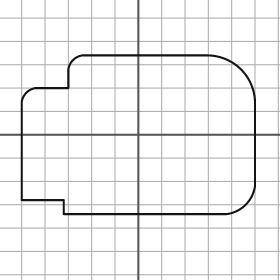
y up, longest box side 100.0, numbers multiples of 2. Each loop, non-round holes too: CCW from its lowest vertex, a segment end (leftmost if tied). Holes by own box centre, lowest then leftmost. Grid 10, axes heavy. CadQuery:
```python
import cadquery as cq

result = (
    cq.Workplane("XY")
    .moveTo(-32.0, -34.0)
    .lineTo(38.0, -34.0)
    .threePointArc((46.0, -30.0), (50.0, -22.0))
    .lineTo(50.0, 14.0)
    .threePointArc((44.0, 28.0), (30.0, 34.0))
    .lineTo(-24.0, 34.0)
    .threePointArc((-28.0, 32.0), (-30.0, 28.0))
    .lineTo(-30.0, 20.0)
    .lineTo(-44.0, 20.0)
    .threePointArc((-48.0, 18.0), (-50.0, 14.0))
    .lineTo(-50.0, -28.0)
    .lineTo(-32.0, -28.0)
    .close()
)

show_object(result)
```